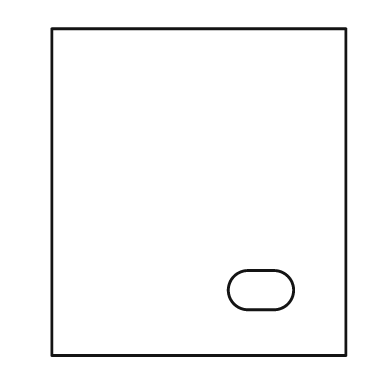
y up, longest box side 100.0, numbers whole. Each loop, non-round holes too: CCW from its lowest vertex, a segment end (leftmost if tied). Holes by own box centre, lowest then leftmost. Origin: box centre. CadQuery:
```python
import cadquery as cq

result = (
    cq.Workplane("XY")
    .moveTo(-45.0, -50.0)
    .lineTo(45.0, -50.0)
    .lineTo(45.0, 50.0)
    .lineTo(-45.0, 50.0)
    .close()
    .moveTo(15.0, -36.0)
    .lineTo(23.0, -36.0)
    .threePointArc((29.0, -30.0), (23.0, -24.0))
    .lineTo(15.0, -24.0)
    .threePointArc((9.0, -30.0), (15.0, -36.0))
    .close()
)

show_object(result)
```